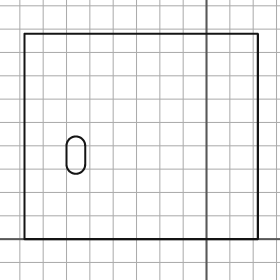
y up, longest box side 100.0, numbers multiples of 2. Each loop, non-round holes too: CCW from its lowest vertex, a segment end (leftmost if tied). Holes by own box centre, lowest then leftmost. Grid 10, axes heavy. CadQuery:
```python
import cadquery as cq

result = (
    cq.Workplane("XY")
    .moveTo(-78.0, 0.0)
    .lineTo(22.0, 0.0)
    .lineTo(22.0, 88.0)
    .lineTo(-78.0, 88.0)
    .close()
    .moveTo(-60.0, 32.0)
    .threePointArc((-56.0, 28.0), (-52.0, 32.0))
    .lineTo(-52.0, 40.0)
    .threePointArc((-56.0, 44.0), (-60.0, 40.0))
    .close()
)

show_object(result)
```